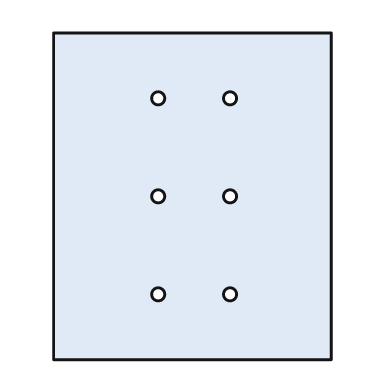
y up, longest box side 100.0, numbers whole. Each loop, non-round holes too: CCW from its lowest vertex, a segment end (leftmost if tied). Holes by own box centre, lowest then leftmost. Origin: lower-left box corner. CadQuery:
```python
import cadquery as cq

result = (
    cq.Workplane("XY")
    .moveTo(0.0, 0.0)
    .lineTo(85.0, 0.0)
    .lineTo(85.0, 100.0)
    .lineTo(0.0, 100.0)
    .close()
    .moveTo(32.0, 20.0)
    .circle(2.0)
    .moveTo(54.0, 20.0)
    .circle(2.0)
    .moveTo(32.0, 50.0)
    .circle(2.0)
    .moveTo(54.0, 50.0)
    .circle(2.0)
    .moveTo(32.0, 80.0)
    .circle(2.0)
    .moveTo(54.0, 80.0)
    .circle(2.0)
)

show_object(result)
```